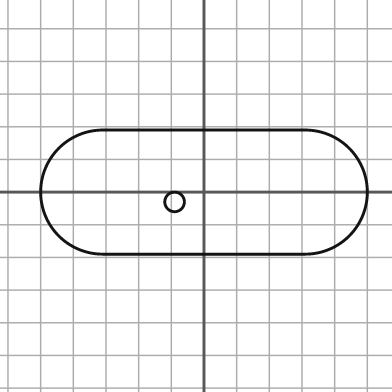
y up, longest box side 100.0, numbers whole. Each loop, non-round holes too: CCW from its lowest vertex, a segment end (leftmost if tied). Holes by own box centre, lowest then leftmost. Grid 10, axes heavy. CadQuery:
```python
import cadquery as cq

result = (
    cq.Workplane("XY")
    .moveTo(-31.0, -19.0)
    .lineTo(31.0, -19.0)
    .threePointArc((50.0, 0.0), (31.0, 19.0))
    .lineTo(-31.0, 19.0)
    .threePointArc((-50.0, 0.0), (-31.0, -19.0))
    .close()
    .moveTo(-9.0, -3.0)
    .circle(3.0)
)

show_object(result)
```